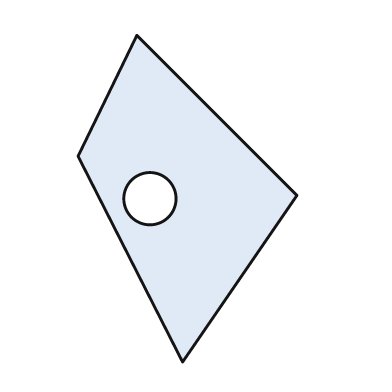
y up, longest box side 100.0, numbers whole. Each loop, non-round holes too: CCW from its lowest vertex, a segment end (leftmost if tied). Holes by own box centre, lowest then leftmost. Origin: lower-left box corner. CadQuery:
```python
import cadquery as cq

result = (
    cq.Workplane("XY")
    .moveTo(32.0, 0.0)
    .lineTo(67.0, 51.0)
    .lineTo(18.0, 100.0)
    .lineTo(0.0, 63.0)
    .close()
    .moveTo(22.0, 50.0)
    .circle(8.0)
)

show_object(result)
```